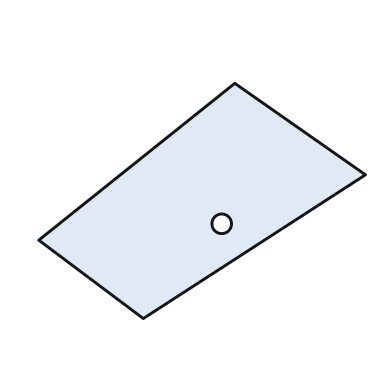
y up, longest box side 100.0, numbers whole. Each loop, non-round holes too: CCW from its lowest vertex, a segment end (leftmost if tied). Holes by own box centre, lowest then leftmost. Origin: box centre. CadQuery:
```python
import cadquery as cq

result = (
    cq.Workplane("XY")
    .moveTo(-18.0, -36.0)
    .lineTo(50.0, 8.0)
    .lineTo(10.0, 36.0)
    .lineTo(-50.0, -12.0)
    .close()
    .moveTo(6.0, -7.0)
    .circle(3.0)
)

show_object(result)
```